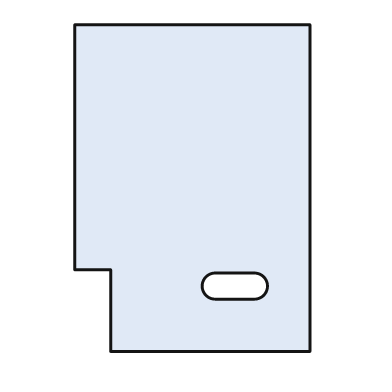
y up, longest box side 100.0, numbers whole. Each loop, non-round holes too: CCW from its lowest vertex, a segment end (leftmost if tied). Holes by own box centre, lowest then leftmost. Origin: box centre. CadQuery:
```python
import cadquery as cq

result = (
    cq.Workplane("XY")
    .moveTo(-25.0, -50.0)
    .lineTo(36.0, -50.0)
    .lineTo(36.0, 50.0)
    .lineTo(-36.0, 50.0)
    .lineTo(-36.0, -25.0)
    .lineTo(-25.0, -25.0)
    .close()
    .moveTo(7.0, -34.0)
    .lineTo(19.0, -34.0)
    .threePointArc((23.0, -30.0), (19.0, -26.0))
    .lineTo(7.0, -26.0)
    .threePointArc((3.0, -30.0), (7.0, -34.0))
    .close()
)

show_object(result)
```